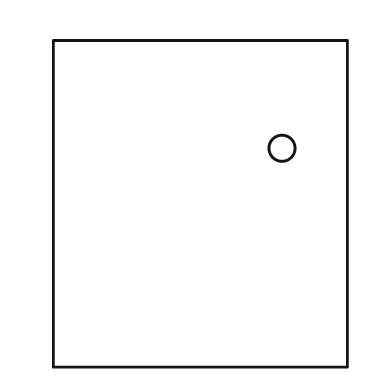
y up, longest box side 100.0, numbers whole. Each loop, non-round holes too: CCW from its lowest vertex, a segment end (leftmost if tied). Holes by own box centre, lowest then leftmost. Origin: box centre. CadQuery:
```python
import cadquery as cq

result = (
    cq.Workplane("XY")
    .moveTo(-45.0, -50.0)
    .lineTo(45.0, -50.0)
    .lineTo(45.0, 50.0)
    .lineTo(-45.0, 50.0)
    .close()
    .moveTo(25.0, 17.0)
    .circle(4.0)
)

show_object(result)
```